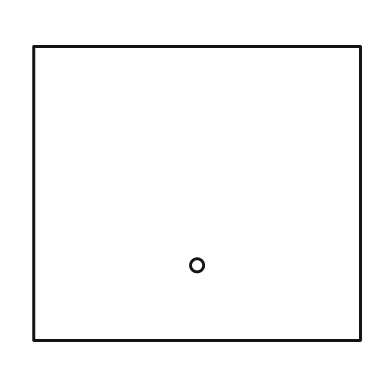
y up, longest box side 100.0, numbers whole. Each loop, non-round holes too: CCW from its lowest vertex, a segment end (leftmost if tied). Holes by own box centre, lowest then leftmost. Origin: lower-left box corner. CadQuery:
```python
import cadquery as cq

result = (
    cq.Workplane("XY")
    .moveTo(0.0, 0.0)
    .lineTo(100.0, 0.0)
    .lineTo(100.0, 90.0)
    .lineTo(0.0, 90.0)
    .close()
    .moveTo(50.0, 23.0)
    .circle(2.0)
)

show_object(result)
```